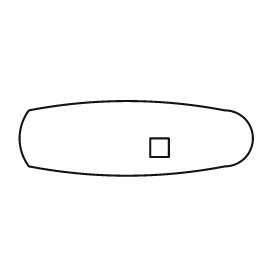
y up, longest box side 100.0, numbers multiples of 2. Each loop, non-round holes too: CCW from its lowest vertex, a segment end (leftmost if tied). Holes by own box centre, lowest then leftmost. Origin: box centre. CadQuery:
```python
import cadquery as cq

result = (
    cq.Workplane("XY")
    .moveTo(-46.0, -12.0)
    .threePointArc((-4.0, -16.0), (38.0, -12.0))
    .threePointArc((50.0, 0.0), (38.0, 12.0))
    .threePointArc((-4.0, 16.0), (-46.0, 12.0))
    .threePointArc((-50.0, 0.0), (-46.0, -12.0))
    .close()
    .moveTo(6.0, -8.0)
    .lineTo(14.0, -8.0)
    .lineTo(14.0, 0.0)
    .lineTo(6.0, 0.0)
    .close()
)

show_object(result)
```